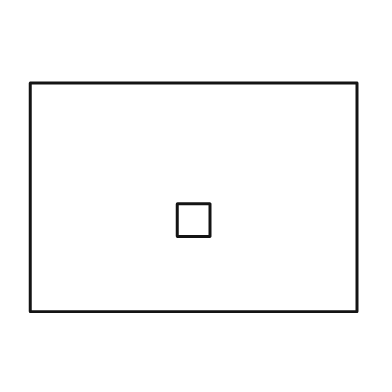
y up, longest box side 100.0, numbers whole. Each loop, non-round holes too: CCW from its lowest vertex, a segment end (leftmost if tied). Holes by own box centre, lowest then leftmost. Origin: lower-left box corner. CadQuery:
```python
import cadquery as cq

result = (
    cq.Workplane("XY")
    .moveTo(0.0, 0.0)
    .lineTo(100.0, 0.0)
    .lineTo(100.0, 70.0)
    .lineTo(0.0, 70.0)
    .close()
    .moveTo(45.0, 23.0)
    .lineTo(55.0, 23.0)
    .lineTo(55.0, 33.0)
    .lineTo(45.0, 33.0)
    .close()
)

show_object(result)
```